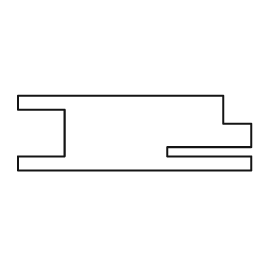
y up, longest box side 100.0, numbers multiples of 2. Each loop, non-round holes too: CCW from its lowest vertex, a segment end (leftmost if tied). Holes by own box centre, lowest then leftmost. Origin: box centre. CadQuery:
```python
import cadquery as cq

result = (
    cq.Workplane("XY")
    .moveTo(-50.0, -16.0)
    .lineTo(50.0, -16.0)
    .lineTo(50.0, -10.0)
    .lineTo(14.0, -10.0)
    .lineTo(14.0, -6.0)
    .lineTo(50.0, -6.0)
    .lineTo(50.0, 4.0)
    .lineTo(38.0, 4.0)
    .lineTo(38.0, 16.0)
    .lineTo(-50.0, 16.0)
    .lineTo(-50.0, 10.0)
    .lineTo(-30.0, 10.0)
    .lineTo(-30.0, -10.0)
    .lineTo(-50.0, -10.0)
    .close()
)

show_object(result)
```